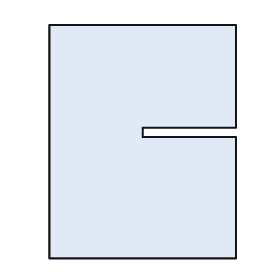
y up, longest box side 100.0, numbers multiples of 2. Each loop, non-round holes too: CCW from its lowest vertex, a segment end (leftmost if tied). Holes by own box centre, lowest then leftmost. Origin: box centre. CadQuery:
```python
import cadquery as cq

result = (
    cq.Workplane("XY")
    .moveTo(-40.0, -50.0)
    .lineTo(40.0, -50.0)
    .lineTo(40.0, 2.0)
    .lineTo(0.0, 2.0)
    .lineTo(0.0, 6.0)
    .lineTo(40.0, 6.0)
    .lineTo(40.0, 50.0)
    .lineTo(-40.0, 50.0)
    .close()
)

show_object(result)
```